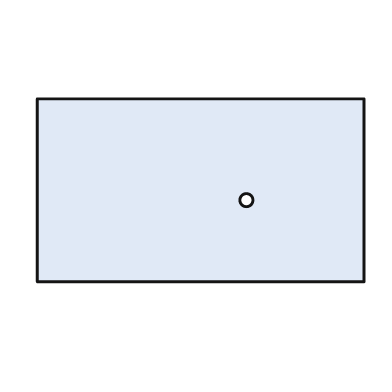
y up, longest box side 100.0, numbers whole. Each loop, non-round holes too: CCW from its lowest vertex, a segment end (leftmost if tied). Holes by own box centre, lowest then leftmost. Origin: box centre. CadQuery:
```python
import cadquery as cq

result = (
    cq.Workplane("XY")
    .moveTo(-50.0, -28.0)
    .lineTo(50.0, -28.0)
    .lineTo(50.0, 28.0)
    .lineTo(-50.0, 28.0)
    .close()
    .moveTo(14.0, -3.0)
    .circle(2.0)
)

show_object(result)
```